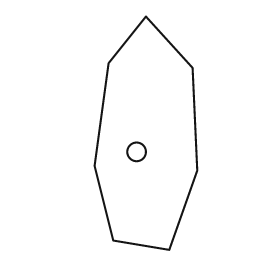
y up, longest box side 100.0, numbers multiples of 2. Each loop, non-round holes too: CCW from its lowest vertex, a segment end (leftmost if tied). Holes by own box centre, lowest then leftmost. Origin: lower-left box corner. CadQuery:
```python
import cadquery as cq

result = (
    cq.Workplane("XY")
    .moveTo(32.0, 0.0)
    .lineTo(44.0, 34.0)
    .lineTo(42.0, 78.0)
    .lineTo(22.0, 100.0)
    .lineTo(6.0, 80.0)
    .lineTo(0.0, 36.0)
    .lineTo(8.0, 4.0)
    .close()
    .moveTo(18.0, 42.0)
    .circle(4.0)
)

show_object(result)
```